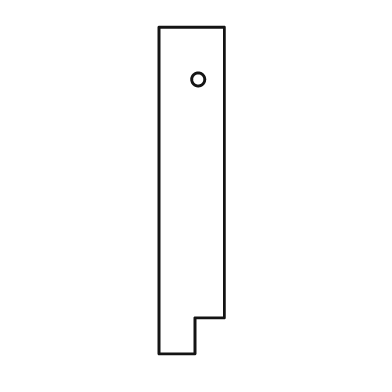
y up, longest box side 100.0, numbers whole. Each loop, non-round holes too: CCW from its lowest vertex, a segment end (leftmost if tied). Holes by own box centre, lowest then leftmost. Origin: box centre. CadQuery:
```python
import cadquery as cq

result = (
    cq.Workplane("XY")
    .moveTo(-10.0, -50.0)
    .lineTo(1.0, -50.0)
    .lineTo(1.0, -39.0)
    .lineTo(10.0, -39.0)
    .lineTo(10.0, 50.0)
    .lineTo(-10.0, 50.0)
    .close()
    .moveTo(2.0, 34.0)
    .circle(2.0)
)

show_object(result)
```